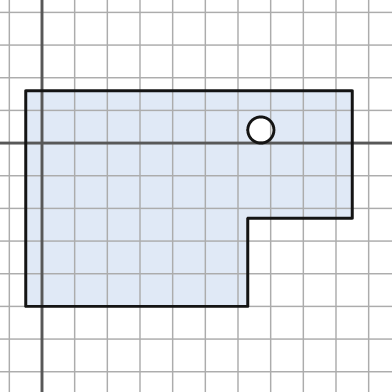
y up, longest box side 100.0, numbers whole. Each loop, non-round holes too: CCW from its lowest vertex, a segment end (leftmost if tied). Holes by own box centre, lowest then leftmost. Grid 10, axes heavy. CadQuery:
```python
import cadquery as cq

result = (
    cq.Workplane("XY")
    .moveTo(-5.0, -50.0)
    .lineTo(63.0, -50.0)
    .lineTo(63.0, -23.0)
    .lineTo(95.0, -23.0)
    .lineTo(95.0, 16.0)
    .lineTo(-5.0, 16.0)
    .close()
    .moveTo(67.0, 4.0)
    .circle(4.0)
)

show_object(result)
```